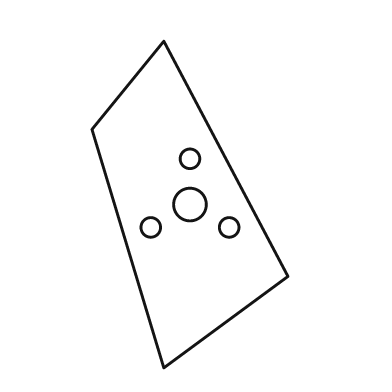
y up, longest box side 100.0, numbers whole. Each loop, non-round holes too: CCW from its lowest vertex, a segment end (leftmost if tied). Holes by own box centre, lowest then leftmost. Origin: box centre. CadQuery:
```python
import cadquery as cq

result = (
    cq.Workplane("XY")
    .moveTo(-8.0, -50.0)
    .lineTo(30.0, -22.0)
    .lineTo(-8.0, 50.0)
    .lineTo(-30.0, 23.0)
    .close()
    .moveTo(-12.0, -7.0)
    .circle(3.0)
    .moveTo(12.0, -7.0)
    .circle(3.0)
    .moveTo(0.0, 0.0)
    .circle(5.0)
    .moveTo(0.0, 14.0)
    .circle(3.0)
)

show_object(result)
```